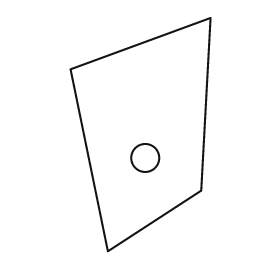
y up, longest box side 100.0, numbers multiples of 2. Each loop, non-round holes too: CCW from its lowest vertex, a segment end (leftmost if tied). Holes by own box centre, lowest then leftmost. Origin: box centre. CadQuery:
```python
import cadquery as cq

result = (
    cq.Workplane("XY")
    .moveTo(-14.0, -50.0)
    .lineTo(26.0, -24.0)
    .lineTo(30.0, 50.0)
    .lineTo(-30.0, 28.0)
    .close()
    .moveTo(2.0, -10.0)
    .circle(6.0)
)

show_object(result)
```